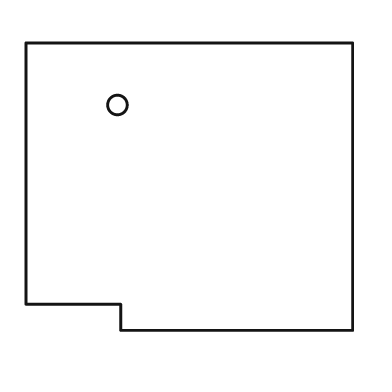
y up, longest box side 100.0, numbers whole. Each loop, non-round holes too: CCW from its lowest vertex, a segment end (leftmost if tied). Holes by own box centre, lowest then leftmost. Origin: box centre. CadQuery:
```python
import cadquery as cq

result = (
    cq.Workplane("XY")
    .moveTo(-21.0, -44.0)
    .lineTo(50.0, -44.0)
    .lineTo(50.0, 44.0)
    .lineTo(-50.0, 44.0)
    .lineTo(-50.0, -36.0)
    .lineTo(-21.0, -36.0)
    .close()
    .moveTo(-22.0, 25.0)
    .circle(3.0)
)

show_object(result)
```